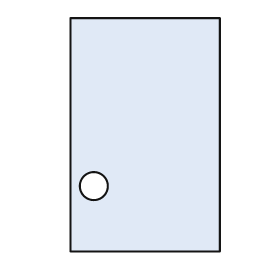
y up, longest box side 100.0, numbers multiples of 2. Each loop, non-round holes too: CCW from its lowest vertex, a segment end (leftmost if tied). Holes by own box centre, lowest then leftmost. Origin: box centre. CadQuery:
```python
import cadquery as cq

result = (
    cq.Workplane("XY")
    .moveTo(-32.0, -50.0)
    .lineTo(32.0, -50.0)
    .lineTo(32.0, 50.0)
    .lineTo(-32.0, 50.0)
    .close()
    .moveTo(-22.0, -22.0)
    .circle(6.0)
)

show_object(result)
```